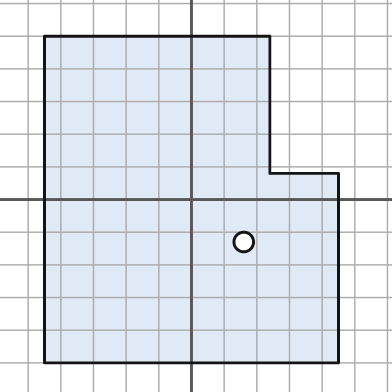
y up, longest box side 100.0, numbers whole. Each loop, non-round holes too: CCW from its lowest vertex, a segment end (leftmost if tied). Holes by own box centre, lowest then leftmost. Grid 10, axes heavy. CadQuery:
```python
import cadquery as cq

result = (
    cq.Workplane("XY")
    .moveTo(-45.0, -50.0)
    .lineTo(45.0, -50.0)
    .lineTo(45.0, 8.0)
    .lineTo(24.0, 8.0)
    .lineTo(24.0, 50.0)
    .lineTo(-45.0, 50.0)
    .close()
    .moveTo(16.0, -13.0)
    .circle(3.0)
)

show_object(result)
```